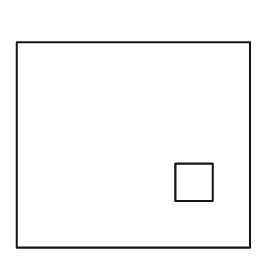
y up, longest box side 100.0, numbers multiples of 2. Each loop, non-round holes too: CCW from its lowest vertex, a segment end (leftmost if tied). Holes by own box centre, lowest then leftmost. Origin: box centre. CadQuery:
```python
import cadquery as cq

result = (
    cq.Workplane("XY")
    .moveTo(-50.0, -44.0)
    .lineTo(50.0, -44.0)
    .lineTo(50.0, 44.0)
    .lineTo(-50.0, 44.0)
    .close()
    .moveTo(18.0, -24.0)
    .lineTo(34.0, -24.0)
    .lineTo(34.0, -8.0)
    .lineTo(18.0, -8.0)
    .close()
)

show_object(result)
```